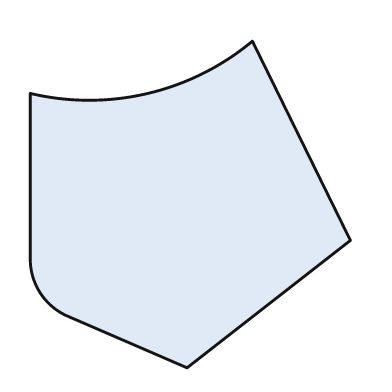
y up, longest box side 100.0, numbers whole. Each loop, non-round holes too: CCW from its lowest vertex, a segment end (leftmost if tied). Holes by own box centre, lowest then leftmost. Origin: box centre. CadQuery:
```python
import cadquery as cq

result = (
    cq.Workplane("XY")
    .moveTo(-1.0, -50.0)
    .lineTo(49.0, -11.0)
    .lineTo(19.0, 50.0)
    .threePointArc((-13.0, 34.0), (-49.0, 34.0))
    .lineTo(-49.0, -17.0)
    .threePointArc((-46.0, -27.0), (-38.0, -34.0))
    .close()
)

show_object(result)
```